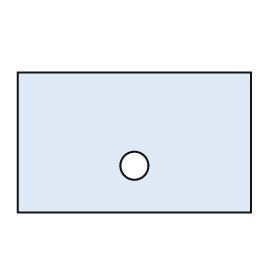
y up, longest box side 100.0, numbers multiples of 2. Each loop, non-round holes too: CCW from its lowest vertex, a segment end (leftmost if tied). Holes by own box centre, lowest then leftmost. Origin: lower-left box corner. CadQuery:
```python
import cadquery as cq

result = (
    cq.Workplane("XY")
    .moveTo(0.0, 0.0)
    .lineTo(100.0, 0.0)
    .lineTo(100.0, 60.0)
    .lineTo(0.0, 60.0)
    .close()
    .moveTo(50.0, 20.0)
    .circle(6.0)
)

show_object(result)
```